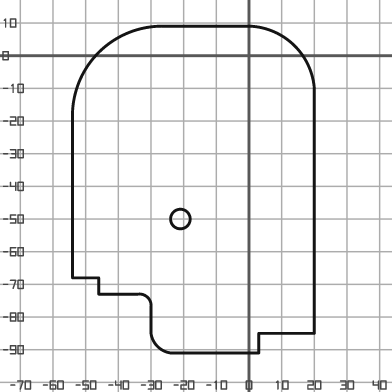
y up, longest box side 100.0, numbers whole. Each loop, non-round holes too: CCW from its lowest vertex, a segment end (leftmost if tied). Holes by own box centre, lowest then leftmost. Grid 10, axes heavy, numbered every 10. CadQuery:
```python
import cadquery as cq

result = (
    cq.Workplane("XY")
    .moveTo(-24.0, -91.0)
    .lineTo(3.0, -91.0)
    .lineTo(3.0, -85.0)
    .lineTo(20.0, -85.0)
    .lineTo(20.0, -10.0)
    .threePointArc((14.0, 3.0), (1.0, 9.0))
    .lineTo(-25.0, 9.0)
    .threePointArc((-46.0, 1.0), (-54.0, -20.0))
    .lineTo(-54.0, -68.0)
    .lineTo(-46.0, -68.0)
    .lineTo(-46.0, -73.0)
    .lineTo(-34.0, -73.0)
    .threePointArc((-31.0, -74.0), (-30.0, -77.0))
    .lineTo(-30.0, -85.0)
    .threePointArc((-28.0, -89.0), (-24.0, -91.0))
    .close()
    .moveTo(-21.0, -50.0)
    .circle(3.0)
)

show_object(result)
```